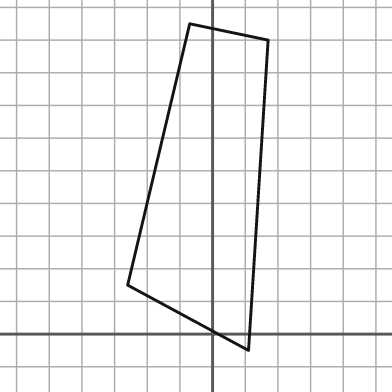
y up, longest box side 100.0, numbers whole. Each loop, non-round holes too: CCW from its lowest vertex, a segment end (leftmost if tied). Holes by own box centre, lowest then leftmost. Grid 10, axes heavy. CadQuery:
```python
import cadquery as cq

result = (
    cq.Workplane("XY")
    .moveTo(11.0, -5.0)
    .lineTo(17.0, 90.0)
    .lineTo(-7.0, 95.0)
    .lineTo(-26.0, 15.0)
    .close()
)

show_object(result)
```